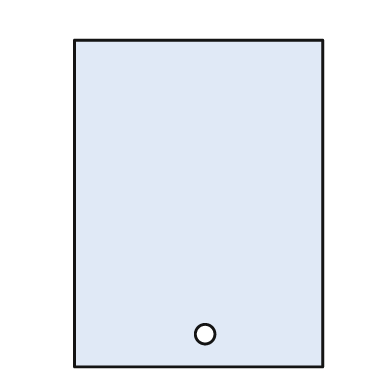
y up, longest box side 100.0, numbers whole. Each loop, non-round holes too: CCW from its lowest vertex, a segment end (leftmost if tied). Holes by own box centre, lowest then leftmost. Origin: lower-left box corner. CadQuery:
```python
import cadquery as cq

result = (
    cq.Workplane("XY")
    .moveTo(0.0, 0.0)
    .lineTo(76.0, 0.0)
    .lineTo(76.0, 100.0)
    .lineTo(0.0, 100.0)
    .close()
    .moveTo(40.0, 10.0)
    .circle(3.0)
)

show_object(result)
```